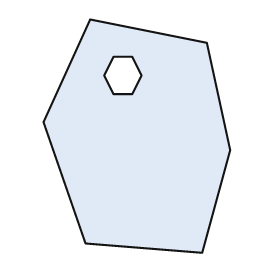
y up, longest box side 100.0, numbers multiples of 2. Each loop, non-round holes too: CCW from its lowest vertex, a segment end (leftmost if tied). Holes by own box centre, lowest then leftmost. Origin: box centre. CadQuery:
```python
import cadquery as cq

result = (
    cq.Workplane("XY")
    .moveTo(28.0, -50.0)
    .lineTo(40.0, -6.0)
    .lineTo(30.0, 40.0)
    .lineTo(-20.0, 50.0)
    .lineTo(-40.0, 6.0)
    .lineTo(-22.0, -46.0)
    .close()
    .moveTo(-10.0, 18.0)
    .lineTo(-2.0, 18.0)
    .lineTo(2.0, 26.0)
    .lineTo(-2.0, 34.0)
    .lineTo(-10.0, 34.0)
    .lineTo(-14.0, 26.0)
    .close()
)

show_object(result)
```